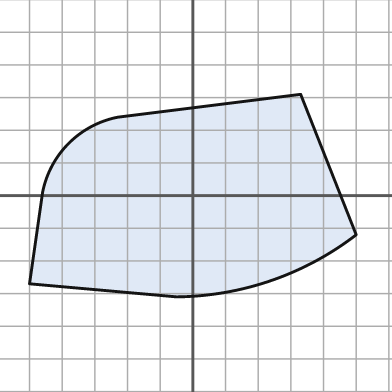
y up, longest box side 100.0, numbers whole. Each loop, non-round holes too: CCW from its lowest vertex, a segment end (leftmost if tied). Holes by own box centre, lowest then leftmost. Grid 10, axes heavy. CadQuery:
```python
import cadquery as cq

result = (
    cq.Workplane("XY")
    .moveTo(-5.0, -31.0)
    .threePointArc((24.0, -26.0), (50.0, -12.0))
    .lineTo(33.0, 31.0)
    .lineTo(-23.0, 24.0)
    .threePointArc((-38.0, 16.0), (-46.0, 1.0))
    .lineTo(-50.0, -27.0)
    .close()
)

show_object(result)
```